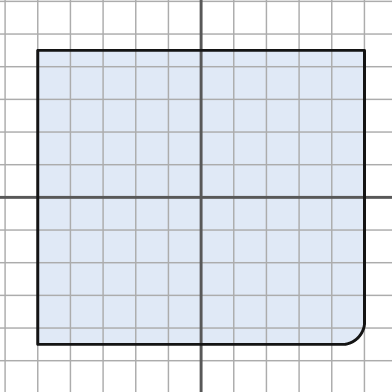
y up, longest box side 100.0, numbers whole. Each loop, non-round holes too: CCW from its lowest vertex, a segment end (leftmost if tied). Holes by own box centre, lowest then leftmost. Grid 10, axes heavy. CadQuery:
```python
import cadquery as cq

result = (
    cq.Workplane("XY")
    .moveTo(-50.0, -45.0)
    .lineTo(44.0, -45.0)
    .threePointArc((48.0, -43.0), (50.0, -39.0))
    .lineTo(50.0, 45.0)
    .lineTo(-50.0, 45.0)
    .close()
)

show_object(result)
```